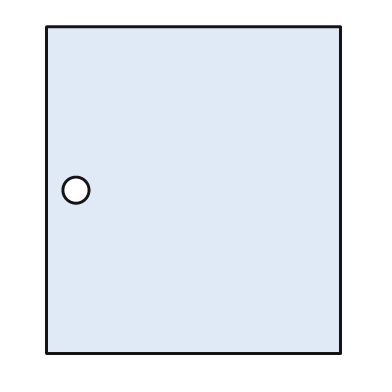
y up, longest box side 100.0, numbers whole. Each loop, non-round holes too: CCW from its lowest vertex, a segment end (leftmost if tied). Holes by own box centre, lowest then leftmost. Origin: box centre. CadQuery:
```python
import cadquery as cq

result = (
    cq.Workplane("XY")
    .moveTo(-45.0, -50.0)
    .lineTo(45.0, -50.0)
    .lineTo(45.0, 50.0)
    .lineTo(-45.0, 50.0)
    .close()
    .moveTo(-36.0, 0.0)
    .circle(4.0)
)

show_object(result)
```